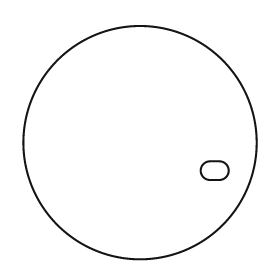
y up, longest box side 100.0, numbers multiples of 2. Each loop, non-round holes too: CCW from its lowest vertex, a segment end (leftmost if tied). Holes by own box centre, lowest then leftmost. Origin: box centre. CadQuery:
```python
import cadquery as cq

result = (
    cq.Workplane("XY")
    .moveTo(0.0, 0.0)
    .circle(50.0)
    .moveTo(30.0, -16.0)
    .lineTo(34.0, -16.0)
    .threePointArc((38.0, -12.0), (34.0, -8.0))
    .lineTo(30.0, -8.0)
    .threePointArc((26.0, -12.0), (30.0, -16.0))
    .close()
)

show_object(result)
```